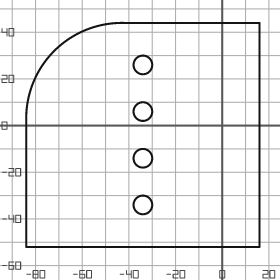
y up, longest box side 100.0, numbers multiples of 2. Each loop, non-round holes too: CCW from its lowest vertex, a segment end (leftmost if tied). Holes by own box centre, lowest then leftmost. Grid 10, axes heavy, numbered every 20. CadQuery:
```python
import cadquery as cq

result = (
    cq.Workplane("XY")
    .moveTo(-84.0, -52.0)
    .lineTo(16.0, -52.0)
    .lineTo(16.0, 44.0)
    .lineTo(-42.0, 44.0)
    .threePointArc((-72.0, 32.0), (-84.0, 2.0))
    .close()
    .moveTo(-34.0, -34.0)
    .circle(4.0)
    .moveTo(-34.0, -14.0)
    .circle(4.0)
    .moveTo(-34.0, 6.0)
    .circle(4.0)
    .moveTo(-34.0, 26.0)
    .circle(4.0)
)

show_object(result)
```